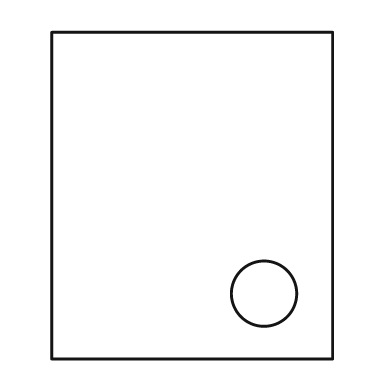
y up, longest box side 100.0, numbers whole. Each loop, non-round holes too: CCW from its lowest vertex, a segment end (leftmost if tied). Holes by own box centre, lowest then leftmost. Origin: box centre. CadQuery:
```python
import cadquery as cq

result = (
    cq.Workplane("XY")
    .moveTo(-43.0, -50.0)
    .lineTo(43.0, -50.0)
    .lineTo(43.0, 50.0)
    .lineTo(-43.0, 50.0)
    .close()
    .moveTo(22.0, -30.0)
    .circle(10.0)
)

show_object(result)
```